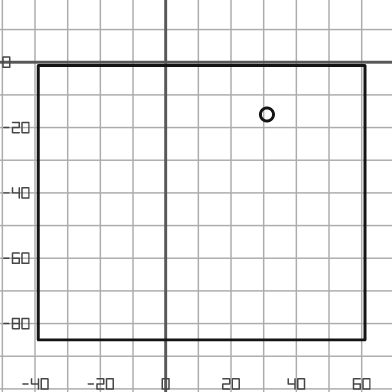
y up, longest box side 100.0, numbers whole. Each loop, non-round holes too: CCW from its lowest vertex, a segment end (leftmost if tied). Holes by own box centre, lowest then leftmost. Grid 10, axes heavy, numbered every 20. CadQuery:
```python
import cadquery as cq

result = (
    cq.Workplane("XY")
    .moveTo(-39.0, -85.0)
    .lineTo(61.0, -85.0)
    .lineTo(61.0, -1.0)
    .lineTo(-39.0, -1.0)
    .close()
    .moveTo(31.0, -16.0)
    .circle(2.0)
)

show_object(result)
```